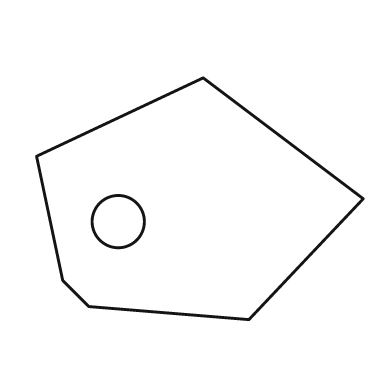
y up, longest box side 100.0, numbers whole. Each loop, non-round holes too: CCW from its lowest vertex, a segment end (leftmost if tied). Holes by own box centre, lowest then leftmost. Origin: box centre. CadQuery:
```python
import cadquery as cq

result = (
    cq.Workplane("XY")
    .moveTo(15.0, -37.0)
    .lineTo(50.0, 0.0)
    .lineTo(1.0, 37.0)
    .lineTo(-50.0, 13.0)
    .lineTo(-42.0, -25.0)
    .lineTo(-34.0, -33.0)
    .close()
    .moveTo(-25.0, -7.0)
    .circle(8.0)
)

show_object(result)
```